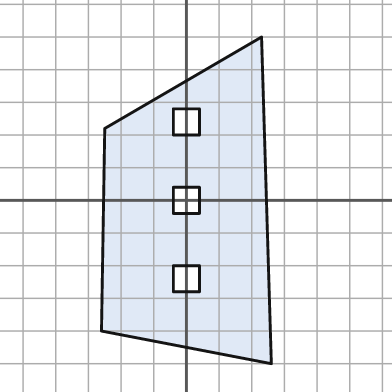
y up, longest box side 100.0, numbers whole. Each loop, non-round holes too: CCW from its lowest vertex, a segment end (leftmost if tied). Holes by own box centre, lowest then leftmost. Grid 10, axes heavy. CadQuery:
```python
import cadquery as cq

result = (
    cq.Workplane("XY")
    .moveTo(26.0, -50.0)
    .lineTo(23.0, 50.0)
    .lineTo(-25.0, 22.0)
    .lineTo(-26.0, -40.0)
    .close()
    .moveTo(-4.0, -28.0)
    .lineTo(4.0, -28.0)
    .lineTo(4.0, -20.0)
    .lineTo(-4.0, -20.0)
    .close()
    .moveTo(-4.0, -4.0)
    .lineTo(4.0, -4.0)
    .lineTo(4.0, 4.0)
    .lineTo(-4.0, 4.0)
    .close()
    .moveTo(-4.0, 20.0)
    .lineTo(4.0, 20.0)
    .lineTo(4.0, 28.0)
    .lineTo(-4.0, 28.0)
    .close()
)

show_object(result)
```